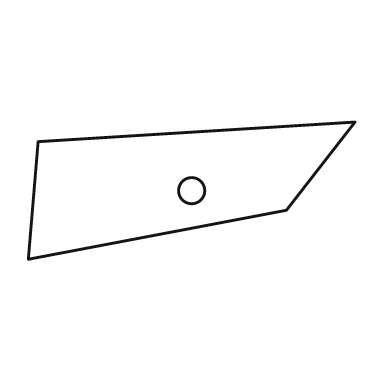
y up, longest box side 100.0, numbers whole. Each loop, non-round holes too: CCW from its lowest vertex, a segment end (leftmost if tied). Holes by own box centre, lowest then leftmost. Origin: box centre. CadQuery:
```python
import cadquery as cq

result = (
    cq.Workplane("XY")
    .moveTo(-50.0, -21.0)
    .lineTo(29.0, -6.0)
    .lineTo(50.0, 21.0)
    .lineTo(-47.0, 15.0)
    .close()
    .moveTo(0.0, 0.0)
    .circle(4.0)
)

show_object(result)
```